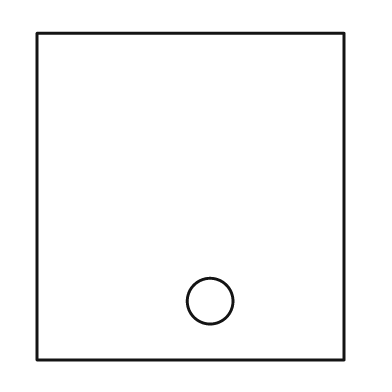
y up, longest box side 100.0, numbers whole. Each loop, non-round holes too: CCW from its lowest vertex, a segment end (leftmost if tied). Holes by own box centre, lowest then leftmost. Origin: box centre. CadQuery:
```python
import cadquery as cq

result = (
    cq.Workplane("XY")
    .moveTo(-47.0, -50.0)
    .lineTo(47.0, -50.0)
    .lineTo(47.0, 50.0)
    .lineTo(-47.0, 50.0)
    .close()
    .moveTo(6.0, -32.0)
    .circle(7.0)
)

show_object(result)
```